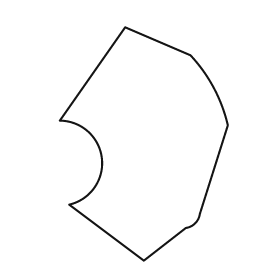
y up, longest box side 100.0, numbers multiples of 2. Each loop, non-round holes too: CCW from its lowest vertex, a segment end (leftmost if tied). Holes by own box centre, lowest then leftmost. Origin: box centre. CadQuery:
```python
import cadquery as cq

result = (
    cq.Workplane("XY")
    .moveTo(0.0, -50.0)
    .lineTo(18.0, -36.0)
    .threePointArc((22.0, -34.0), (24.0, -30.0))
    .lineTo(36.0, 8.0)
    .threePointArc((30.0, 24.0), (20.0, 38.0))
    .lineTo(-8.0, 50.0)
    .lineTo(-36.0, 10.0)
    .threePointArc((-18.0, -6.0), (-32.0, -26.0))
    .close()
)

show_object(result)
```